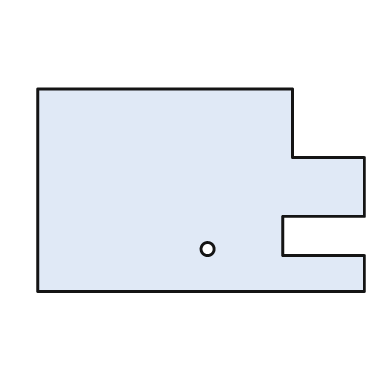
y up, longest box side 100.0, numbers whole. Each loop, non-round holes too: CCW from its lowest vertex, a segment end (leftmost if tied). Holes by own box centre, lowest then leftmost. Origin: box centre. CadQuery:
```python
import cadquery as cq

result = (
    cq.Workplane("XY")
    .moveTo(-50.0, -31.0)
    .lineTo(50.0, -31.0)
    .lineTo(50.0, -20.0)
    .lineTo(25.0, -20.0)
    .lineTo(25.0, -8.0)
    .lineTo(50.0, -8.0)
    .lineTo(50.0, 10.0)
    .lineTo(28.0, 10.0)
    .lineTo(28.0, 31.0)
    .lineTo(-50.0, 31.0)
    .close()
    .moveTo(2.0, -18.0)
    .circle(2.0)
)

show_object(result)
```